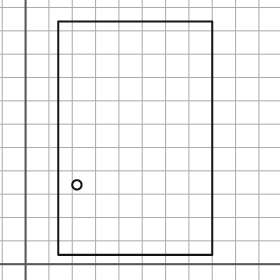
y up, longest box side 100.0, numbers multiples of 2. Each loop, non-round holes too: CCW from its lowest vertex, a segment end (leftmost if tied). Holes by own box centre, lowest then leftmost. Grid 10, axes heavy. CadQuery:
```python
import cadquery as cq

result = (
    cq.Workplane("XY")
    .moveTo(14.0, 4.0)
    .lineTo(80.0, 4.0)
    .lineTo(80.0, 104.0)
    .lineTo(14.0, 104.0)
    .close()
    .moveTo(22.0, 34.0)
    .circle(2.0)
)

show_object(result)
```